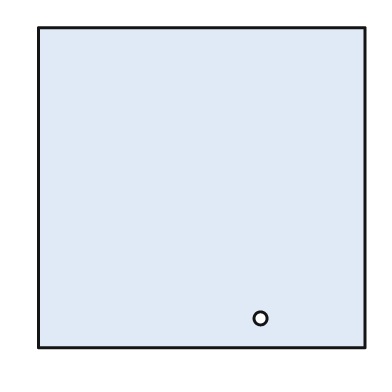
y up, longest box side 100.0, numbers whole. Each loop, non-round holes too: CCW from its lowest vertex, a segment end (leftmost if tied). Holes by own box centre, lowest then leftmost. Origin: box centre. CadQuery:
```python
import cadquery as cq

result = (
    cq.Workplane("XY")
    .moveTo(-50.0, -49.0)
    .lineTo(50.0, -49.0)
    .lineTo(50.0, 49.0)
    .lineTo(-50.0, 49.0)
    .close()
    .moveTo(18.0, -40.0)
    .circle(2.0)
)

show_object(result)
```